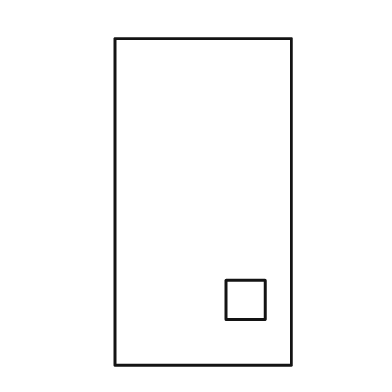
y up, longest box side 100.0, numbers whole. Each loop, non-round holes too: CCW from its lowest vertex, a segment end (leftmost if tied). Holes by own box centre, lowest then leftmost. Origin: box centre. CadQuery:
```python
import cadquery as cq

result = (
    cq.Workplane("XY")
    .moveTo(-27.0, -50.0)
    .lineTo(27.0, -50.0)
    .lineTo(27.0, 50.0)
    .lineTo(-27.0, 50.0)
    .close()
    .moveTo(7.0, -36.0)
    .lineTo(19.0, -36.0)
    .lineTo(19.0, -24.0)
    .lineTo(7.0, -24.0)
    .close()
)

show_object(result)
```